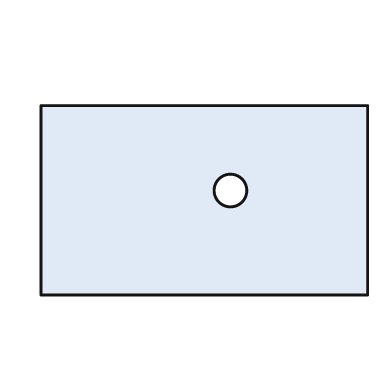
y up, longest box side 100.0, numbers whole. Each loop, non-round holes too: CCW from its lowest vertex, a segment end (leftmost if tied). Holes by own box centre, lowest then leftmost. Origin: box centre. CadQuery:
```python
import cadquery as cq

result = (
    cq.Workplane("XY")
    .moveTo(-50.0, -29.0)
    .lineTo(50.0, -29.0)
    .lineTo(50.0, 29.0)
    .lineTo(-50.0, 29.0)
    .close()
    .moveTo(8.0, 3.0)
    .circle(5.0)
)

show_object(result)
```